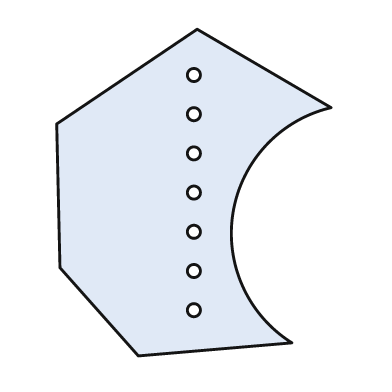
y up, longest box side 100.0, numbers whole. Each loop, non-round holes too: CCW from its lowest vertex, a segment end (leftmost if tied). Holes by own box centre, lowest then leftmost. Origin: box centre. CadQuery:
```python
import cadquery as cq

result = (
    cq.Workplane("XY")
    .moveTo(-17.0, -50.0)
    .lineTo(30.0, -46.0)
    .threePointArc((12.0, -6.0), (42.0, 26.0))
    .lineTo(1.0, 50.0)
    .lineTo(-42.0, 21.0)
    .lineTo(-41.0, -23.0)
    .close()
    .moveTo(0.0, -36.0)
    .circle(2.0)
    .moveTo(0.0, -24.0)
    .circle(2.0)
    .moveTo(0.0, -12.0)
    .circle(2.0)
    .moveTo(0.0, 0.0)
    .circle(2.0)
    .moveTo(0.0, 12.0)
    .circle(2.0)
    .moveTo(0.0, 24.0)
    .circle(2.0)
    .moveTo(0.0, 36.0)
    .circle(2.0)
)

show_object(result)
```